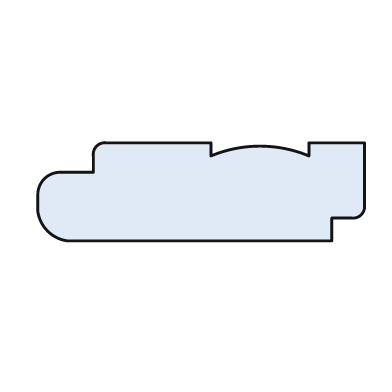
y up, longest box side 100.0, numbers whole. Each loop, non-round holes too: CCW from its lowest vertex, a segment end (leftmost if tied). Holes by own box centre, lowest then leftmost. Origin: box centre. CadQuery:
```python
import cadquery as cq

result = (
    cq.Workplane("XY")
    .moveTo(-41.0, -15.0)
    .lineTo(40.0, -15.0)
    .lineTo(40.0, -8.0)
    .lineTo(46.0, -8.0)
    .threePointArc((49.0, -7.0), (50.0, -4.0))
    .lineTo(50.0, 15.0)
    .lineTo(33.0, 15.0)
    .lineTo(33.0, 11.0)
    .threePointArc((18.0, 14.0), (3.0, 11.0))
    .lineTo(3.0, 15.0)
    .lineTo(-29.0, 15.0)
    .threePointArc((-32.0, 14.0), (-33.0, 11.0))
    .lineTo(-33.0, 6.0)
    .lineTo(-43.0, 6.0)
    .threePointArc((-48.0, 4.0), (-50.0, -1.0))
    .lineTo(-50.0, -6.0)
    .threePointArc((-47.0, -12.0), (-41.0, -15.0))
    .close()
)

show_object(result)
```